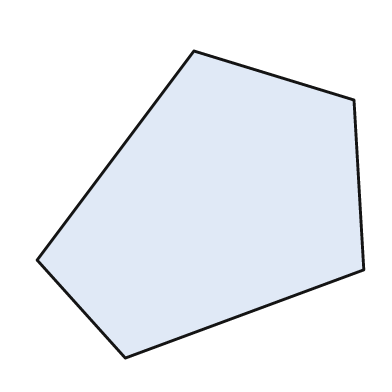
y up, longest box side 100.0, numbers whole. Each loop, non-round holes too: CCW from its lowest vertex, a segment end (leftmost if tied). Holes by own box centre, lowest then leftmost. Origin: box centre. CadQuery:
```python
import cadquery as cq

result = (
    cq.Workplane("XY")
    .moveTo(-23.0, -47.0)
    .lineTo(50.0, -20.0)
    .lineTo(47.0, 32.0)
    .lineTo(-2.0, 47.0)
    .lineTo(-50.0, -17.0)
    .close()
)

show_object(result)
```